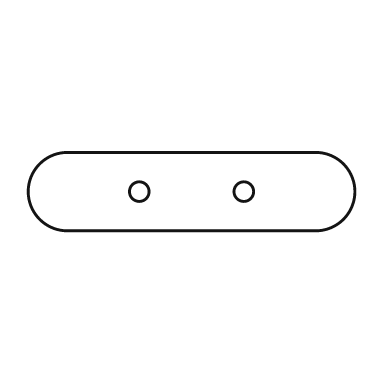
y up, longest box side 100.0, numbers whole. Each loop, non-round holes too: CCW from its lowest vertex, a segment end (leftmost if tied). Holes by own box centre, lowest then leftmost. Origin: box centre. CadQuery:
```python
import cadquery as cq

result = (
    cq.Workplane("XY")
    .moveTo(-38.0, -12.0)
    .lineTo(38.0, -12.0)
    .threePointArc((50.0, 0.0), (38.0, 12.0))
    .lineTo(-38.0, 12.0)
    .threePointArc((-50.0, 0.0), (-38.0, -12.0))
    .close()
    .moveTo(-16.0, 0.0)
    .circle(3.0)
    .moveTo(16.0, 0.0)
    .circle(3.0)
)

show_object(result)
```